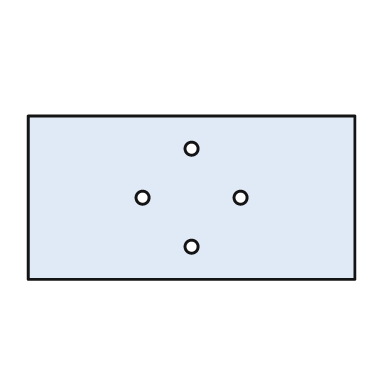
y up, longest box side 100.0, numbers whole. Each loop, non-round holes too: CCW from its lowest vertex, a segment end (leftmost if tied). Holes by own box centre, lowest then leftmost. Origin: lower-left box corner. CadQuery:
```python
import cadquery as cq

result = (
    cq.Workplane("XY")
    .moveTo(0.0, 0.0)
    .lineTo(100.0, 0.0)
    .lineTo(100.0, 50.0)
    .lineTo(0.0, 50.0)
    .close()
    .moveTo(50.0, 10.0)
    .circle(2.0)
    .moveTo(35.0, 25.0)
    .circle(2.0)
    .moveTo(65.0, 25.0)
    .circle(2.0)
    .moveTo(50.0, 40.0)
    .circle(2.0)
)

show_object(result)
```